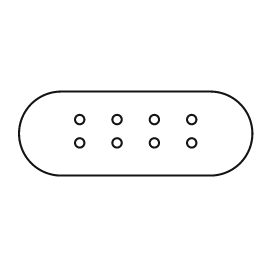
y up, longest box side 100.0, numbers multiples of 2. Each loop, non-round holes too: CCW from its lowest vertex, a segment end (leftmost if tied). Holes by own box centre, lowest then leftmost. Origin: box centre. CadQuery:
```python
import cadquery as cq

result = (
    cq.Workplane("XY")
    .moveTo(-32.0, -18.0)
    .lineTo(32.0, -18.0)
    .threePointArc((50.0, 0.0), (32.0, 18.0))
    .lineTo(-32.0, 18.0)
    .threePointArc((-50.0, 0.0), (-32.0, -18.0))
    .close()
    .moveTo(-24.0, -4.0)
    .circle(2.0)
    .moveTo(-8.0, -4.0)
    .circle(2.0)
    .moveTo(8.0, -4.0)
    .circle(2.0)
    .moveTo(24.0, -4.0)
    .circle(2.0)
    .moveTo(-24.0, 6.0)
    .circle(2.0)
    .moveTo(-8.0, 6.0)
    .circle(2.0)
    .moveTo(8.0, 6.0)
    .circle(2.0)
    .moveTo(24.0, 6.0)
    .circle(2.0)
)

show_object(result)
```